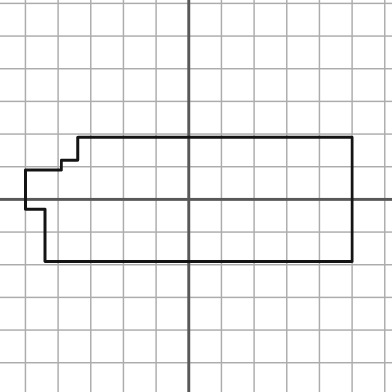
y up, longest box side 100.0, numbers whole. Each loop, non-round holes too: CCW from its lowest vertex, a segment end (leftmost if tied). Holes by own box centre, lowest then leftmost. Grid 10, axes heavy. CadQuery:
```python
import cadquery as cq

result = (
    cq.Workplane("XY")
    .moveTo(-44.0, -19.0)
    .lineTo(50.0, -19.0)
    .lineTo(50.0, 19.0)
    .lineTo(-34.0, 19.0)
    .lineTo(-34.0, 12.0)
    .lineTo(-39.0, 12.0)
    .lineTo(-39.0, 9.0)
    .lineTo(-50.0, 9.0)
    .lineTo(-50.0, -3.0)
    .lineTo(-44.0, -3.0)
    .close()
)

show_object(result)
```